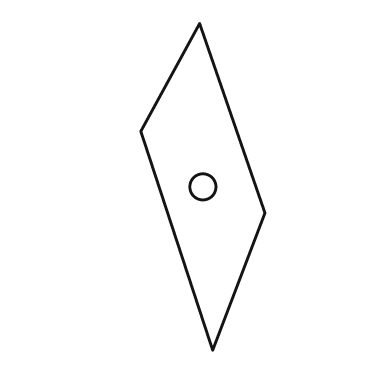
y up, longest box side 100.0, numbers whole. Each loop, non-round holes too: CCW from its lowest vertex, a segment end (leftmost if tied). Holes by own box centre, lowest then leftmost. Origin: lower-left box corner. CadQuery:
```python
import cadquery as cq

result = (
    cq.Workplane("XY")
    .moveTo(22.0, 0.0)
    .lineTo(38.0, 42.0)
    .lineTo(18.0, 100.0)
    .lineTo(0.0, 67.0)
    .close()
    .moveTo(19.0, 50.0)
    .circle(4.0)
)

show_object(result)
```